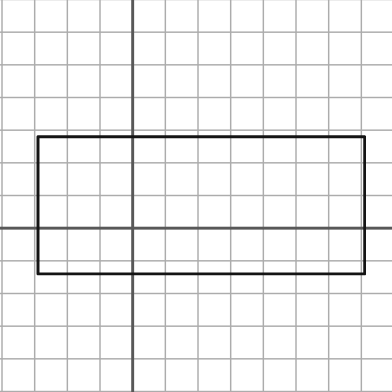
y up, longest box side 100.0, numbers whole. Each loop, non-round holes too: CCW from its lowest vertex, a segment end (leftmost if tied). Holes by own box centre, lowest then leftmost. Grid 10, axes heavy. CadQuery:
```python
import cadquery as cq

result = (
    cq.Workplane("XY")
    .moveTo(-29.0, -14.0)
    .lineTo(71.0, -14.0)
    .lineTo(71.0, 28.0)
    .lineTo(-29.0, 28.0)
    .close()
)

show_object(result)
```